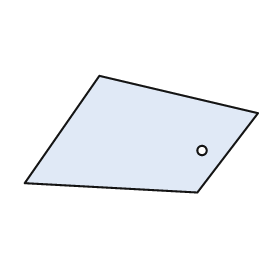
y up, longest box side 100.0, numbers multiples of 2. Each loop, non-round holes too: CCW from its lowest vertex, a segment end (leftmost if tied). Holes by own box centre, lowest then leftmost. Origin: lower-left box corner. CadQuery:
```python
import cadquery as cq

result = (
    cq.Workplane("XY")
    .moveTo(74.0, 0.0)
    .lineTo(100.0, 34.0)
    .lineTo(32.0, 50.0)
    .lineTo(0.0, 4.0)
    .close()
    .moveTo(76.0, 18.0)
    .circle(2.0)
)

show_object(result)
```